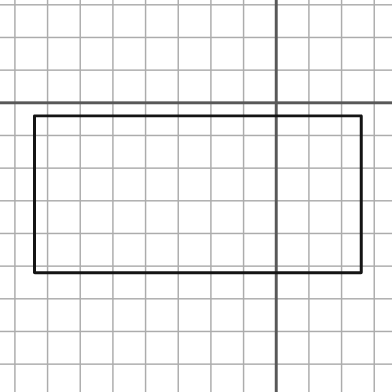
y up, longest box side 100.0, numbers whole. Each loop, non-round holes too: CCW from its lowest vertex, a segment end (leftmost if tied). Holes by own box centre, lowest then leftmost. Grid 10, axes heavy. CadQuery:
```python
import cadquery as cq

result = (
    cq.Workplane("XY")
    .moveTo(-74.0, -52.0)
    .lineTo(26.0, -52.0)
    .lineTo(26.0, -4.0)
    .lineTo(-74.0, -4.0)
    .close()
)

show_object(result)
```